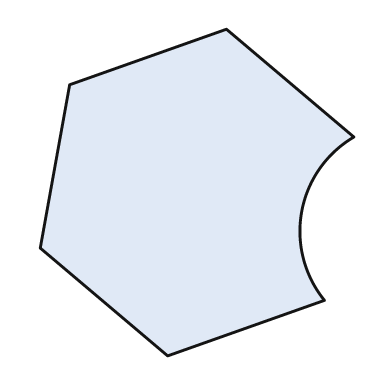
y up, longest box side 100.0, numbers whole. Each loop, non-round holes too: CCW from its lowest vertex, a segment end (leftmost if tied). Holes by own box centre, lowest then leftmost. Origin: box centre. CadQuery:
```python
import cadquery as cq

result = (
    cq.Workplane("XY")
    .moveTo(-9.0, -50.0)
    .lineTo(39.0, -33.0)
    .threePointArc((32.0, -6.0), (48.0, 17.0))
    .lineTo(9.0, 50.0)
    .lineTo(-39.0, 33.0)
    .lineTo(-48.0, -17.0)
    .close()
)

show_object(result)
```